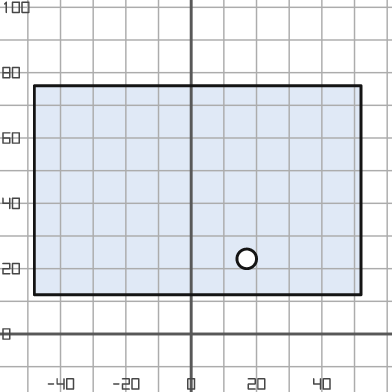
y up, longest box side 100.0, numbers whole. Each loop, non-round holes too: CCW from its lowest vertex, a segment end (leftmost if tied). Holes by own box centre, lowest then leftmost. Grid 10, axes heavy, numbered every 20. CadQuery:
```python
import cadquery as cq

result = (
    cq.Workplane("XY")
    .moveTo(-48.0, 12.0)
    .lineTo(52.0, 12.0)
    .lineTo(52.0, 76.0)
    .lineTo(-48.0, 76.0)
    .close()
    .moveTo(17.0, 23.0)
    .circle(3.0)
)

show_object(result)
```